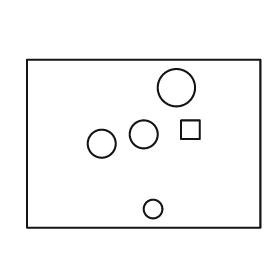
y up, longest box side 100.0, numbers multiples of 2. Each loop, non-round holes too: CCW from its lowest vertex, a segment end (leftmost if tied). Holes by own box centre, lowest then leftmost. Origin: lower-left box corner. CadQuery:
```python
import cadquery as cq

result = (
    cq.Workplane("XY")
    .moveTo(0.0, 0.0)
    .lineTo(100.0, 0.0)
    .lineTo(100.0, 72.0)
    .lineTo(0.0, 72.0)
    .close()
    .moveTo(54.0, 8.0)
    .circle(4.0)
    .moveTo(32.0, 36.0)
    .circle(6.0)
    .moveTo(50.0, 40.0)
    .circle(6.0)
    .moveTo(66.0, 38.0)
    .lineTo(74.0, 38.0)
    .lineTo(74.0, 46.0)
    .lineTo(66.0, 46.0)
    .close()
    .moveTo(64.0, 60.0)
    .circle(8.0)
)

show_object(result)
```